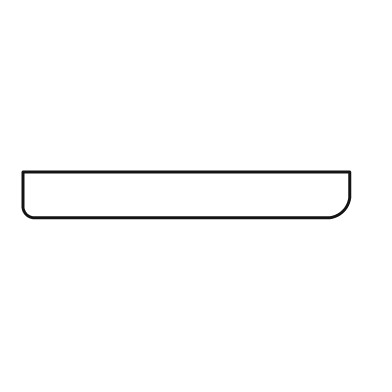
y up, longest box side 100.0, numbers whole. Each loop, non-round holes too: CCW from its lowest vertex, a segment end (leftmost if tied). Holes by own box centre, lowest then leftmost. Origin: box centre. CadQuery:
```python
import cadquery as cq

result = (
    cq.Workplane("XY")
    .moveTo(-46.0, -7.0)
    .lineTo(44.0, -7.0)
    .threePointArc((48.0, -5.0), (50.0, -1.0))
    .lineTo(50.0, 7.0)
    .lineTo(-50.0, 7.0)
    .lineTo(-50.0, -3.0)
    .threePointArc((-49.0, -6.0), (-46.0, -7.0))
    .close()
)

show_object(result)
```